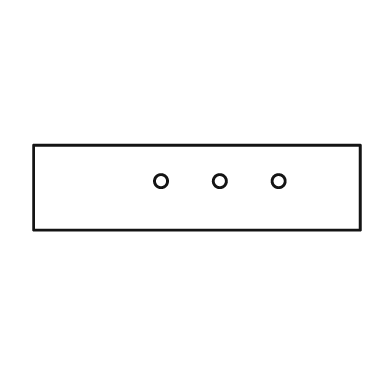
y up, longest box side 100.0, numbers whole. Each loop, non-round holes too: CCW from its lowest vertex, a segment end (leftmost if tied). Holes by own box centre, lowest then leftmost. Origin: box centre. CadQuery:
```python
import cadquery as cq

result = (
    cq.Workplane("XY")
    .moveTo(-50.0, -13.0)
    .lineTo(50.0, -13.0)
    .lineTo(50.0, 13.0)
    .lineTo(-50.0, 13.0)
    .close()
    .moveTo(-11.0, 2.0)
    .circle(2.0)
    .moveTo(7.0, 2.0)
    .circle(2.0)
    .moveTo(25.0, 2.0)
    .circle(2.0)
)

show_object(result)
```